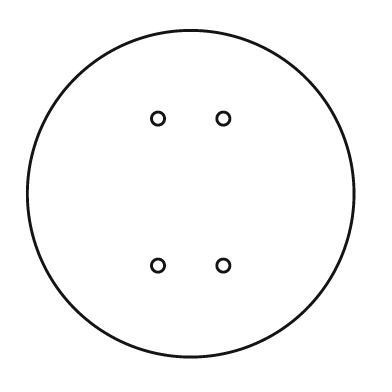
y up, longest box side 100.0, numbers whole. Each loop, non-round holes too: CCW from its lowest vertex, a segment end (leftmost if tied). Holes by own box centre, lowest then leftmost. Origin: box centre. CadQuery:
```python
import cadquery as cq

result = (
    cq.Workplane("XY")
    .moveTo(0.0, 0.0)
    .circle(50.0)
    .moveTo(-10.0, -22.0)
    .circle(2.0)
    .moveTo(10.0, -22.0)
    .circle(2.0)
    .moveTo(-10.0, 23.0)
    .circle(2.0)
    .moveTo(10.0, 23.0)
    .circle(2.0)
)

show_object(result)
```